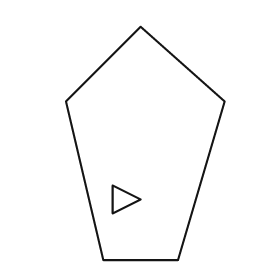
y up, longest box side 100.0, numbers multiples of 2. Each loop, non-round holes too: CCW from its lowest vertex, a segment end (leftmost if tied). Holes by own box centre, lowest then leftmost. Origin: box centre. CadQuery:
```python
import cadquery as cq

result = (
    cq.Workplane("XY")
    .moveTo(-18.0, -50.0)
    .lineTo(14.0, -50.0)
    .lineTo(34.0, 18.0)
    .lineTo(-2.0, 50.0)
    .lineTo(-34.0, 18.0)
    .close()
    .moveTo(-14.0, -30.0)
    .lineTo(-2.0, -24.0)
    .lineTo(-14.0, -18.0)
    .close()
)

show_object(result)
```